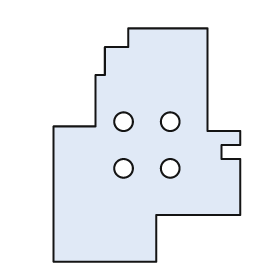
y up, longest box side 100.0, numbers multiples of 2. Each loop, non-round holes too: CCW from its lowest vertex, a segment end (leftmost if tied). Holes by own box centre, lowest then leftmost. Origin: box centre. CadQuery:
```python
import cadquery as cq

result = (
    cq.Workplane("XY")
    .moveTo(-40.0, -50.0)
    .lineTo(4.0, -50.0)
    .lineTo(4.0, -30.0)
    .lineTo(40.0, -30.0)
    .lineTo(40.0, -6.0)
    .lineTo(32.0, -6.0)
    .lineTo(32.0, 0.0)
    .lineTo(40.0, 0.0)
    .lineTo(40.0, 6.0)
    .lineTo(26.0, 6.0)
    .lineTo(26.0, 50.0)
    .lineTo(-8.0, 50.0)
    .lineTo(-8.0, 42.0)
    .lineTo(-18.0, 42.0)
    .lineTo(-18.0, 30.0)
    .lineTo(-22.0, 30.0)
    .lineTo(-22.0, 8.0)
    .lineTo(-40.0, 8.0)
    .close()
    .moveTo(-10.0, -10.0)
    .circle(4.0)
    .moveTo(10.0, -10.0)
    .circle(4.0)
    .moveTo(-10.0, 10.0)
    .circle(4.0)
    .moveTo(10.0, 10.0)
    .circle(4.0)
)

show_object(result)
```